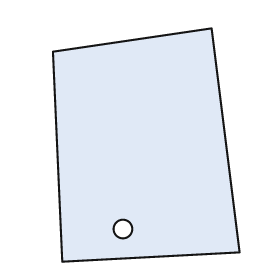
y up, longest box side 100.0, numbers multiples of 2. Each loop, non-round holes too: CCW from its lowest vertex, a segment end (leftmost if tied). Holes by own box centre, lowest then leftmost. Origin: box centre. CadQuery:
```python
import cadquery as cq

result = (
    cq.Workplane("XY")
    .moveTo(-36.0, -50.0)
    .lineTo(40.0, -46.0)
    .lineTo(28.0, 50.0)
    .lineTo(-40.0, 40.0)
    .close()
    .moveTo(-10.0, -36.0)
    .circle(4.0)
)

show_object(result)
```